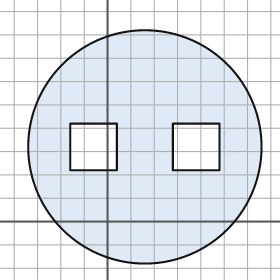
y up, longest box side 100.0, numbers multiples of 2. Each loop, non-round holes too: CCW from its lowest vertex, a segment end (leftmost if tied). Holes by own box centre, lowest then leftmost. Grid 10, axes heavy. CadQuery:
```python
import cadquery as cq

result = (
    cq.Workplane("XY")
    .moveTo(16.0, 32.0)
    .circle(50.0)
    .moveTo(-16.0, 22.0)
    .lineTo(4.0, 22.0)
    .lineTo(4.0, 42.0)
    .lineTo(-16.0, 42.0)
    .close()
    .moveTo(28.0, 22.0)
    .lineTo(48.0, 22.0)
    .lineTo(48.0, 42.0)
    .lineTo(28.0, 42.0)
    .close()
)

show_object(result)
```